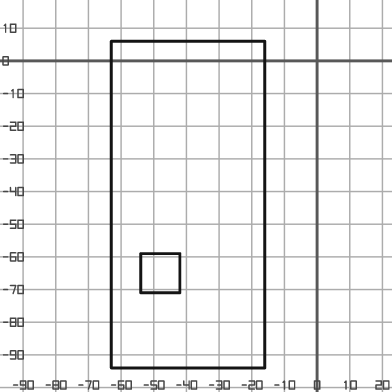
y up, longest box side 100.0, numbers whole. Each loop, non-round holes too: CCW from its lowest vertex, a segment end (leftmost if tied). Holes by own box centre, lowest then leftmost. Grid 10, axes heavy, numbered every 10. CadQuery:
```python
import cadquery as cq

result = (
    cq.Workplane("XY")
    .moveTo(-63.0, -94.0)
    .lineTo(-16.0, -94.0)
    .lineTo(-16.0, 6.0)
    .lineTo(-63.0, 6.0)
    .close()
    .moveTo(-54.0, -71.0)
    .lineTo(-42.0, -71.0)
    .lineTo(-42.0, -59.0)
    .lineTo(-54.0, -59.0)
    .close()
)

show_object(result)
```